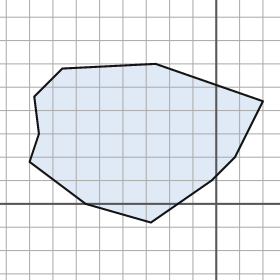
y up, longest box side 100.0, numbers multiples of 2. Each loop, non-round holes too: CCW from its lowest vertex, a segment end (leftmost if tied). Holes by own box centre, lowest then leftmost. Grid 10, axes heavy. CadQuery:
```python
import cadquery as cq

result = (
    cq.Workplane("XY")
    .moveTo(-28.0, -8.0)
    .lineTo(-2.0, 10.0)
    .lineTo(8.0, 20.0)
    .lineTo(20.0, 44.0)
    .lineTo(-26.0, 60.0)
    .lineTo(-66.0, 58.0)
    .lineTo(-78.0, 46.0)
    .lineTo(-76.0, 30.0)
    .lineTo(-80.0, 18.0)
    .lineTo(-56.0, 0.0)
    .close()
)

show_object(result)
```